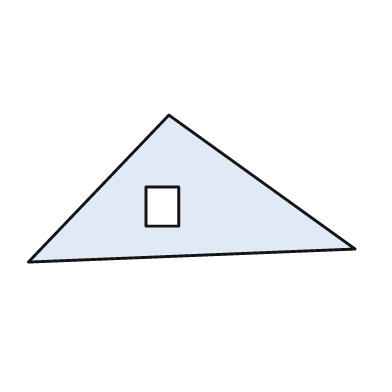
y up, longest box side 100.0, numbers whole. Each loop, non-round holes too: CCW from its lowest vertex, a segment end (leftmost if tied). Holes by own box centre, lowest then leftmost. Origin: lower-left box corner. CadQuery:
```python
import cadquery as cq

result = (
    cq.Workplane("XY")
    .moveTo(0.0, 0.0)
    .lineTo(100.0, 4.0)
    .lineTo(43.0, 45.0)
    .close()
    .moveTo(36.0, 11.0)
    .lineTo(46.0, 11.0)
    .lineTo(46.0, 23.0)
    .lineTo(36.0, 23.0)
    .close()
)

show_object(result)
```